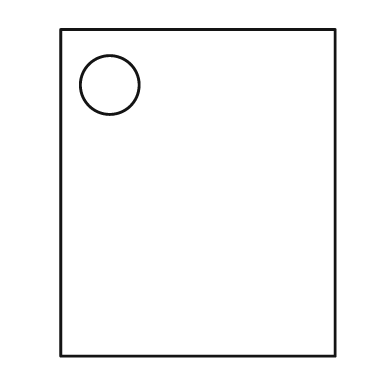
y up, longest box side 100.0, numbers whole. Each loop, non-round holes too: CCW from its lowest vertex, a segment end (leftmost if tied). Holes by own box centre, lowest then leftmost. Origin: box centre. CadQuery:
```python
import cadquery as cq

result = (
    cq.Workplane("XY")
    .moveTo(-42.0, -50.0)
    .lineTo(42.0, -50.0)
    .lineTo(42.0, 50.0)
    .lineTo(-42.0, 50.0)
    .close()
    .moveTo(-27.0, 33.0)
    .circle(9.0)
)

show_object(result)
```